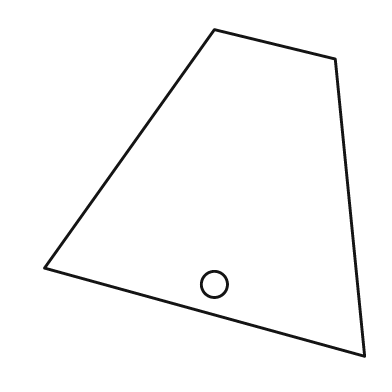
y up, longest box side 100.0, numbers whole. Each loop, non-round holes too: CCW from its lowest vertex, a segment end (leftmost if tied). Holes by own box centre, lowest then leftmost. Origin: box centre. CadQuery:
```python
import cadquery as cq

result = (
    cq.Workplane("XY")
    .moveTo(49.0, -50.0)
    .lineTo(40.0, 41.0)
    .lineTo(3.0, 50.0)
    .lineTo(-49.0, -23.0)
    .close()
    .moveTo(3.0, -28.0)
    .circle(4.0)
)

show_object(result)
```